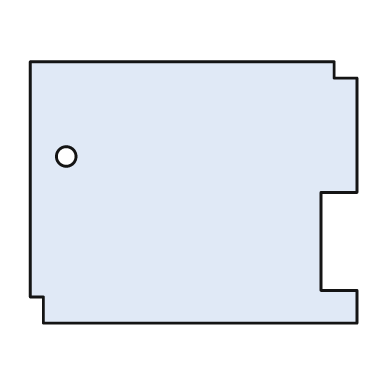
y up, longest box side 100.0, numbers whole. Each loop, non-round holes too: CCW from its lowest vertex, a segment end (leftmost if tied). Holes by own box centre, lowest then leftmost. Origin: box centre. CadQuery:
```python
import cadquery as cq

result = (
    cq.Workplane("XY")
    .moveTo(-46.0, -40.0)
    .lineTo(50.0, -40.0)
    .lineTo(50.0, -30.0)
    .lineTo(39.0, -30.0)
    .lineTo(39.0, 0.0)
    .lineTo(50.0, 0.0)
    .lineTo(50.0, 35.0)
    .lineTo(43.0, 35.0)
    .lineTo(43.0, 40.0)
    .lineTo(-50.0, 40.0)
    .lineTo(-50.0, -32.0)
    .lineTo(-46.0, -32.0)
    .close()
    .moveTo(-39.0, 11.0)
    .circle(3.0)
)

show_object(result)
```